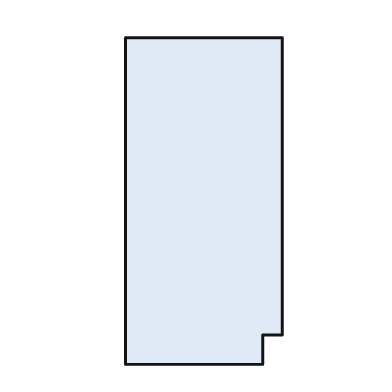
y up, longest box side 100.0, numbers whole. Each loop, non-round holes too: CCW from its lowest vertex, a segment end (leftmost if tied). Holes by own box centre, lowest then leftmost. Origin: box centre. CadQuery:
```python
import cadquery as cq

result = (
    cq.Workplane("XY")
    .moveTo(-24.0, -50.0)
    .lineTo(18.0, -50.0)
    .lineTo(18.0, -41.0)
    .lineTo(24.0, -41.0)
    .lineTo(24.0, 50.0)
    .lineTo(-24.0, 50.0)
    .close()
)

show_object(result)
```